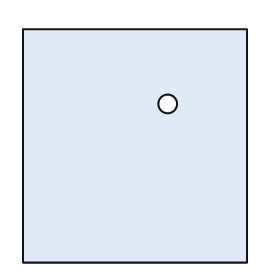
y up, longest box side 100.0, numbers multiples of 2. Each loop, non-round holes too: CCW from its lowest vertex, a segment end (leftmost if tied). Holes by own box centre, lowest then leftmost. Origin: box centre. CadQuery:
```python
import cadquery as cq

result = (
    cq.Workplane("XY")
    .moveTo(-48.0, -50.0)
    .lineTo(48.0, -50.0)
    .lineTo(48.0, 50.0)
    .lineTo(-48.0, 50.0)
    .close()
    .moveTo(14.0, 18.0)
    .circle(4.0)
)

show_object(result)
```